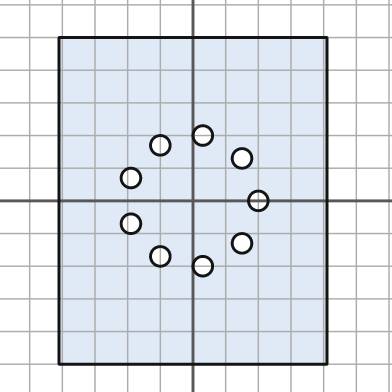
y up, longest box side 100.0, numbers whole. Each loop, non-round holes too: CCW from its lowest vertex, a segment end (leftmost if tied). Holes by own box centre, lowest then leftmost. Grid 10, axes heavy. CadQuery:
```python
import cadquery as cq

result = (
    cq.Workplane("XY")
    .moveTo(-41.0, -50.0)
    .lineTo(41.0, -50.0)
    .lineTo(41.0, 50.0)
    .lineTo(-41.0, 50.0)
    .close()
    .moveTo(3.0, -20.0)
    .circle(3.0)
    .moveTo(-10.0, -17.0)
    .circle(3.0)
    .moveTo(15.0, -13.0)
    .circle(3.0)
    .moveTo(-19.0, -7.0)
    .circle(3.0)
    .moveTo(20.0, 0.0)
    .circle(3.0)
    .moveTo(-19.0, 7.0)
    .circle(3.0)
    .moveTo(15.0, 13.0)
    .circle(3.0)
    .moveTo(-10.0, 17.0)
    .circle(3.0)
    .moveTo(3.0, 20.0)
    .circle(3.0)
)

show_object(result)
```